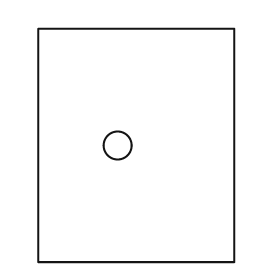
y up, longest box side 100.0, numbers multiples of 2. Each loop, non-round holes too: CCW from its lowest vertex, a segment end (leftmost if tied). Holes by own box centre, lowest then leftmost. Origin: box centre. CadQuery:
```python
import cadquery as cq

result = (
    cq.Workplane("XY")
    .moveTo(-42.0, -50.0)
    .lineTo(42.0, -50.0)
    .lineTo(42.0, 50.0)
    .lineTo(-42.0, 50.0)
    .close()
    .moveTo(-8.0, 0.0)
    .circle(6.0)
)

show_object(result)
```